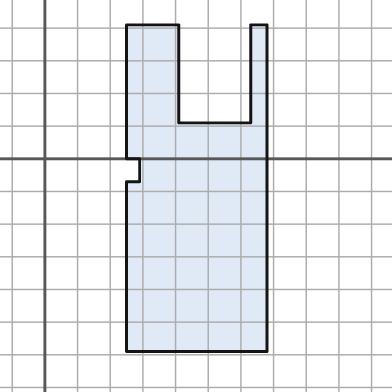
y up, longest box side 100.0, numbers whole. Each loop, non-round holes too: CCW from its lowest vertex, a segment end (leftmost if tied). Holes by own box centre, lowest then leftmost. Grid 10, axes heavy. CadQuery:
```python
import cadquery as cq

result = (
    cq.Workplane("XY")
    .moveTo(25.0, -59.0)
    .lineTo(68.0, -59.0)
    .lineTo(68.0, 41.0)
    .lineTo(63.0, 41.0)
    .lineTo(63.0, 11.0)
    .lineTo(41.0, 11.0)
    .lineTo(41.0, 41.0)
    .lineTo(25.0, 41.0)
    .lineTo(25.0, 0.0)
    .lineTo(29.0, 0.0)
    .lineTo(29.0, -7.0)
    .lineTo(25.0, -7.0)
    .close()
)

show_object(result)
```